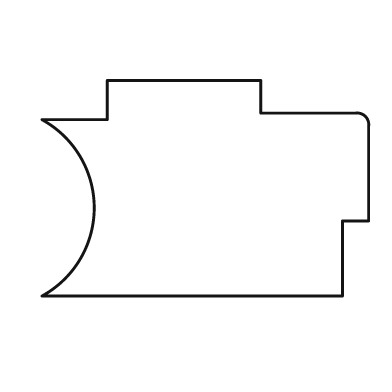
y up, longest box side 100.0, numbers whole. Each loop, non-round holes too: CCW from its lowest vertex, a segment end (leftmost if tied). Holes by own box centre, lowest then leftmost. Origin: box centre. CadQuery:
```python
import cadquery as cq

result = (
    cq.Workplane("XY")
    .moveTo(-50.0, -33.0)
    .lineTo(42.0, -33.0)
    .lineTo(42.0, -10.0)
    .lineTo(50.0, -10.0)
    .lineTo(50.0, 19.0)
    .threePointArc((49.0, 22.0), (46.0, 23.0))
    .lineTo(17.0, 23.0)
    .lineTo(17.0, 33.0)
    .lineTo(-30.0, 33.0)
    .lineTo(-30.0, 21.0)
    .lineTo(-50.0, 21.0)
    .threePointArc((-34.0, -6.0), (-50.0, -33.0))
    .close()
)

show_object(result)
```